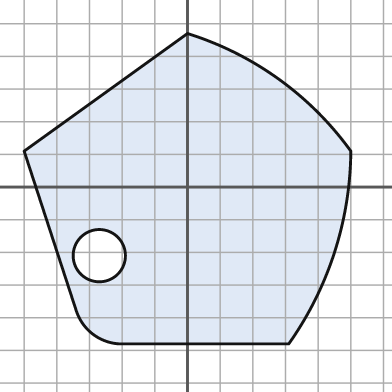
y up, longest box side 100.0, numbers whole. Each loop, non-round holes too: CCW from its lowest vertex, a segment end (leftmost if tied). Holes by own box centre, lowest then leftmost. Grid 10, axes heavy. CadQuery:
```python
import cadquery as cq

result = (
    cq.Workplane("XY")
    .moveTo(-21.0, -48.0)
    .lineTo(31.0, -48.0)
    .threePointArc((45.0, -20.0), (50.0, 11.0))
    .threePointArc((28.0, 33.0), (0.0, 47.0))
    .lineTo(-50.0, 11.0)
    .lineTo(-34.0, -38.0)
    .threePointArc((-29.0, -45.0), (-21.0, -48.0))
    .close()
    .moveTo(-27.0, -21.0)
    .circle(8.0)
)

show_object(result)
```